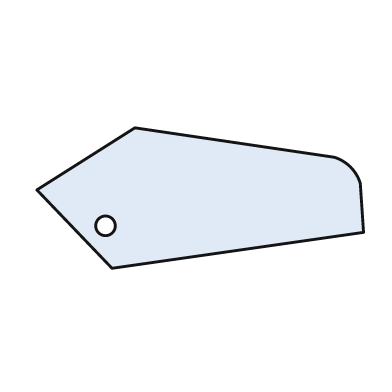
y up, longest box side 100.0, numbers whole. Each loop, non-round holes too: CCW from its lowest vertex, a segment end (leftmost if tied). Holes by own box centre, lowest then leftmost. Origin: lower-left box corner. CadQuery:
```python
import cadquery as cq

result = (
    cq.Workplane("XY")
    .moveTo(23.0, 0.0)
    .lineTo(100.0, 11.0)
    .lineTo(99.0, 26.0)
    .threePointArc((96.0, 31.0), (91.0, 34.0))
    .lineTo(30.0, 43.0)
    .lineTo(0.0, 24.0)
    .close()
    .moveTo(21.0, 13.0)
    .circle(3.0)
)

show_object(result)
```